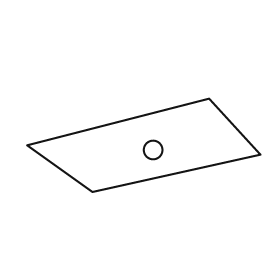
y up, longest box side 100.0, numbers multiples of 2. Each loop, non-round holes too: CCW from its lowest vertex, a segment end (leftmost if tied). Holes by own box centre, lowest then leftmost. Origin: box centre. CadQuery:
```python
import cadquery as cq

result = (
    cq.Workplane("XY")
    .moveTo(-22.0, -20.0)
    .lineTo(50.0, -4.0)
    .lineTo(28.0, 20.0)
    .lineTo(-50.0, 0.0)
    .close()
    .moveTo(4.0, -2.0)
    .circle(4.0)
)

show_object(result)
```